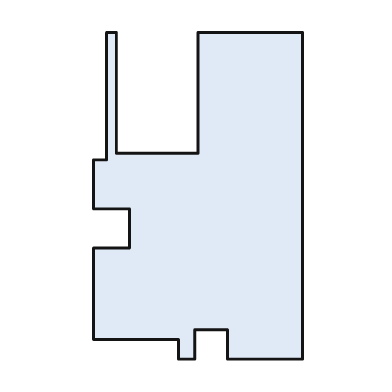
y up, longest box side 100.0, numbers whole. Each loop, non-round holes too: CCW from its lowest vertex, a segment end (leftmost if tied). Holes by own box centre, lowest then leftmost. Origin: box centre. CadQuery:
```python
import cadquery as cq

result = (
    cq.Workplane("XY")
    .moveTo(-6.0, -50.0)
    .lineTo(-1.0, -50.0)
    .lineTo(-1.0, -41.0)
    .lineTo(9.0, -41.0)
    .lineTo(9.0, -50.0)
    .lineTo(32.0, -50.0)
    .lineTo(32.0, 50.0)
    .lineTo(0.0, 50.0)
    .lineTo(0.0, 13.0)
    .lineTo(-25.0, 13.0)
    .lineTo(-25.0, 50.0)
    .lineTo(-28.0, 50.0)
    .lineTo(-28.0, 11.0)
    .lineTo(-32.0, 11.0)
    .lineTo(-32.0, -4.0)
    .lineTo(-21.0, -4.0)
    .lineTo(-21.0, -16.0)
    .lineTo(-32.0, -16.0)
    .lineTo(-32.0, -44.0)
    .lineTo(-6.0, -44.0)
    .close()
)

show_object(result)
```